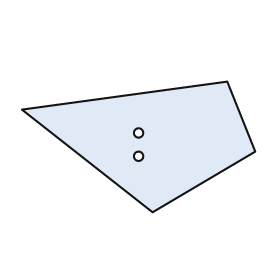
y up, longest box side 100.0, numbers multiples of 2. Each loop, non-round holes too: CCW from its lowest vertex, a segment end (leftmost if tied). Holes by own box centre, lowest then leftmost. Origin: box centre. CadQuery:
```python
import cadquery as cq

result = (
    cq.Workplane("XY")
    .moveTo(6.0, -28.0)
    .lineTo(50.0, -2.0)
    .lineTo(38.0, 28.0)
    .lineTo(-50.0, 16.0)
    .close()
    .moveTo(0.0, -4.0)
    .circle(2.0)
    .moveTo(0.0, 6.0)
    .circle(2.0)
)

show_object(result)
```